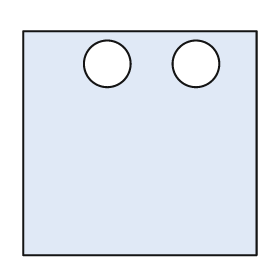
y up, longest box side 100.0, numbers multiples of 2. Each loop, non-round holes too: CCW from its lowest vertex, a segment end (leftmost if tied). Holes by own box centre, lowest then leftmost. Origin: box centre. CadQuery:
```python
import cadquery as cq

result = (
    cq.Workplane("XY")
    .moveTo(-50.0, -48.0)
    .lineTo(50.0, -48.0)
    .lineTo(50.0, 48.0)
    .lineTo(-50.0, 48.0)
    .close()
    .moveTo(-14.0, 34.0)
    .circle(10.0)
    .moveTo(24.0, 34.0)
    .circle(10.0)
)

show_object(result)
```